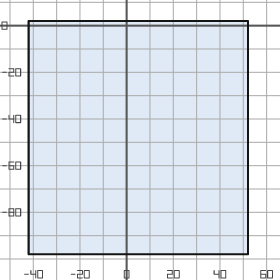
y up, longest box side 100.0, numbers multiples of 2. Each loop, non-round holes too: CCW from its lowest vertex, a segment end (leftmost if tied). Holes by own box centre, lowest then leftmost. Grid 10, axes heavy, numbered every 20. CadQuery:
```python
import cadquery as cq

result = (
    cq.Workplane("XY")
    .moveTo(-42.0, -98.0)
    .lineTo(52.0, -98.0)
    .lineTo(52.0, 2.0)
    .lineTo(-42.0, 2.0)
    .close()
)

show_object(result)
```